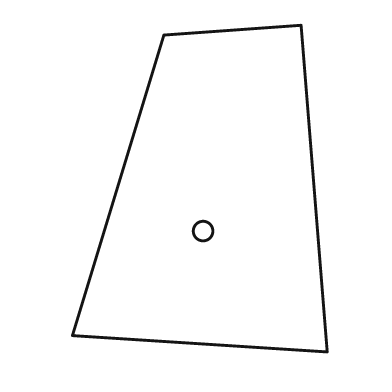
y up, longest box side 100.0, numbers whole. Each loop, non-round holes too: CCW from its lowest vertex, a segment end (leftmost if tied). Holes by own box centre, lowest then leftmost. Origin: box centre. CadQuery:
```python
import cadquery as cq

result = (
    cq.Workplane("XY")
    .moveTo(39.0, -50.0)
    .lineTo(31.0, 50.0)
    .lineTo(-11.0, 47.0)
    .lineTo(-39.0, -45.0)
    .close()
    .moveTo(1.0, -13.0)
    .circle(3.0)
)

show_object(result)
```